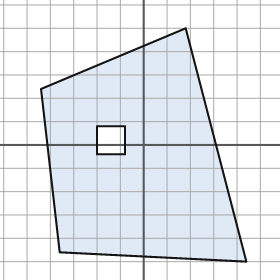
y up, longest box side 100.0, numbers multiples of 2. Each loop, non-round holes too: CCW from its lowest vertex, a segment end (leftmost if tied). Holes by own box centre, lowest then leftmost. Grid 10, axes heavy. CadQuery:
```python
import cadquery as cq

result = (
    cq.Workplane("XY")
    .moveTo(44.0, -50.0)
    .lineTo(18.0, 50.0)
    .lineTo(-44.0, 24.0)
    .lineTo(-36.0, -46.0)
    .close()
    .moveTo(-20.0, -4.0)
    .lineTo(-8.0, -4.0)
    .lineTo(-8.0, 8.0)
    .lineTo(-20.0, 8.0)
    .close()
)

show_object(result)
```